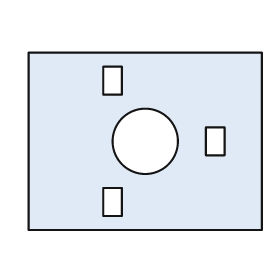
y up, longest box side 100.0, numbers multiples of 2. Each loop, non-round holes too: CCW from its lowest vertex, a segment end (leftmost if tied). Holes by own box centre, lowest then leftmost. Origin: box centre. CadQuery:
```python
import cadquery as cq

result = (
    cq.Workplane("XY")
    .moveTo(-50.0, -38.0)
    .lineTo(50.0, -38.0)
    .lineTo(50.0, 38.0)
    .lineTo(-50.0, 38.0)
    .close()
    .moveTo(-18.0, -32.0)
    .lineTo(-10.0, -32.0)
    .lineTo(-10.0, -20.0)
    .lineTo(-18.0, -20.0)
    .close()
    .moveTo(0.0, 0.0)
    .circle(14.0)
    .moveTo(26.0, -6.0)
    .lineTo(34.0, -6.0)
    .lineTo(34.0, 6.0)
    .lineTo(26.0, 6.0)
    .close()
    .moveTo(-18.0, 20.0)
    .lineTo(-10.0, 20.0)
    .lineTo(-10.0, 32.0)
    .lineTo(-18.0, 32.0)
    .close()
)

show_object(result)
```